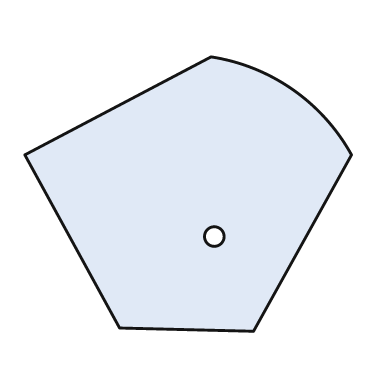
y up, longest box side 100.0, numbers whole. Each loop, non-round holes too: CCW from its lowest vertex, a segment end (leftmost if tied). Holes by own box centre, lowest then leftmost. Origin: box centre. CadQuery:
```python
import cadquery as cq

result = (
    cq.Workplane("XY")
    .moveTo(20.0, -42.0)
    .lineTo(50.0, 12.0)
    .threePointArc((32.0, 32.0), (7.0, 42.0))
    .lineTo(-50.0, 12.0)
    .lineTo(-21.0, -41.0)
    .close()
    .moveTo(8.0, -13.0)
    .circle(3.0)
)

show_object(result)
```